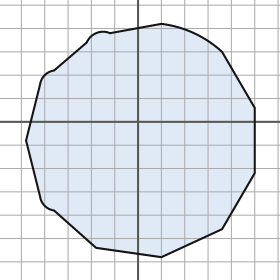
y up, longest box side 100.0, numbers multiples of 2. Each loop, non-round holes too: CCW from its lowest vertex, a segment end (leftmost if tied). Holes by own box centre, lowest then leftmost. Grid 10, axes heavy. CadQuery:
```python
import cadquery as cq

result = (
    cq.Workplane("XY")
    .moveTo(10.0, -58.0)
    .lineTo(36.0, -46.0)
    .lineTo(50.0, -22.0)
    .lineTo(50.0, 6.0)
    .lineTo(36.0, 30.0)
    .threePointArc((24.0, 38.0), (10.0, 42.0))
    .lineTo(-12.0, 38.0)
    .threePointArc((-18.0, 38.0), (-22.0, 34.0))
    .lineTo(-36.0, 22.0)
    .threePointArc((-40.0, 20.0), (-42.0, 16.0))
    .lineTo(-48.0, -8.0)
    .lineTo(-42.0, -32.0)
    .threePointArc((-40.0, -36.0), (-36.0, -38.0))
    .lineTo(-18.0, -54.0)
    .close()
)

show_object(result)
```